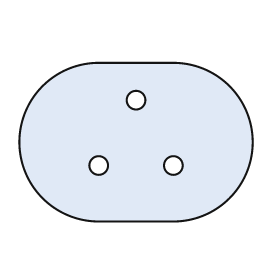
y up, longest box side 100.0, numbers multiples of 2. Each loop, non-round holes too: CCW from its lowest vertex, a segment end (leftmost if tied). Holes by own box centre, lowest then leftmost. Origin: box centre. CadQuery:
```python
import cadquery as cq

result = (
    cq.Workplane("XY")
    .moveTo(-16.0, -34.0)
    .lineTo(16.0, -34.0)
    .threePointArc((50.0, 0.0), (16.0, 34.0))
    .lineTo(-16.0, 34.0)
    .threePointArc((-50.0, 0.0), (-16.0, -34.0))
    .close()
    .moveTo(-16.0, -10.0)
    .circle(4.0)
    .moveTo(16.0, -10.0)
    .circle(4.0)
    .moveTo(0.0, 18.0)
    .circle(4.0)
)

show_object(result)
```